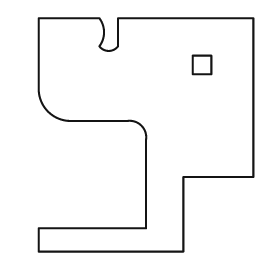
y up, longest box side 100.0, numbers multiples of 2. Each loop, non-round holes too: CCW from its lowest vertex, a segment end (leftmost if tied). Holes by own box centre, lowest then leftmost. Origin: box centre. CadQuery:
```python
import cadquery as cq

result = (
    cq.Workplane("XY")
    .moveTo(-46.0, -50.0)
    .lineTo(16.0, -50.0)
    .lineTo(16.0, -18.0)
    .lineTo(46.0, -18.0)
    .lineTo(46.0, 50.0)
    .lineTo(-12.0, 50.0)
    .lineTo(-12.0, 38.0)
    .threePointArc((-16.0, 36.0), (-20.0, 38.0))
    .threePointArc((-18.0, 44.0), (-20.0, 50.0))
    .lineTo(-46.0, 50.0)
    .lineTo(-46.0, 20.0)
    .threePointArc((-42.0, 10.0), (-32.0, 6.0))
    .lineTo(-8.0, 6.0)
    .threePointArc((-2.0, 4.0), (0.0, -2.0))
    .lineTo(0.0, -40.0)
    .lineTo(-46.0, -40.0)
    .close()
    .moveTo(20.0, 26.0)
    .lineTo(28.0, 26.0)
    .lineTo(28.0, 34.0)
    .lineTo(20.0, 34.0)
    .close()
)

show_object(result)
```